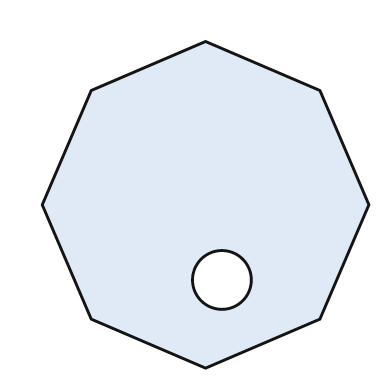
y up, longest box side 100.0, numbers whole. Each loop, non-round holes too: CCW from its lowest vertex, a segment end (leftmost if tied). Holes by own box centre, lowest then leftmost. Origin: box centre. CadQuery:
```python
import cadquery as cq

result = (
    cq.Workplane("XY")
    .moveTo(0.0, -50.0)
    .lineTo(35.0, -35.0)
    .lineTo(50.0, 0.0)
    .lineTo(35.0, 35.0)
    .lineTo(0.0, 50.0)
    .lineTo(-35.0, 35.0)
    .lineTo(-50.0, 0.0)
    .lineTo(-35.0, -35.0)
    .close()
    .moveTo(5.0, -23.0)
    .circle(9.0)
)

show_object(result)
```